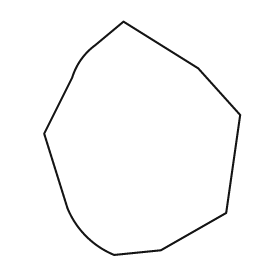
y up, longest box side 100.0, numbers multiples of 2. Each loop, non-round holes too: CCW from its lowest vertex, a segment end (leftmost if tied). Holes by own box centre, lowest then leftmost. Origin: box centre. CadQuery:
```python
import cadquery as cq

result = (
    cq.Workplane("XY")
    .moveTo(-12.0, -50.0)
    .lineTo(8.0, -48.0)
    .lineTo(36.0, -32.0)
    .lineTo(42.0, 10.0)
    .lineTo(24.0, 30.0)
    .lineTo(-8.0, 50.0)
    .lineTo(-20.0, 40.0)
    .threePointArc((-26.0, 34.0), (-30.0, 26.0))
    .lineTo(-42.0, 2.0)
    .lineTo(-32.0, -30.0)
    .threePointArc((-24.0, -42.0), (-12.0, -50.0))
    .close()
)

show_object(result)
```